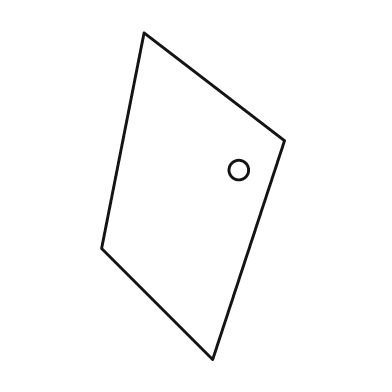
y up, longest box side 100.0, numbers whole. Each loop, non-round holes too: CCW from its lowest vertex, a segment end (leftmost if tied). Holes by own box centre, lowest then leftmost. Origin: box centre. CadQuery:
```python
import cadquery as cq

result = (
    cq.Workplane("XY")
    .moveTo(6.0, -50.0)
    .lineTo(28.0, 17.0)
    .lineTo(-15.0, 50.0)
    .lineTo(-28.0, -16.0)
    .close()
    .moveTo(14.0, 8.0)
    .circle(3.0)
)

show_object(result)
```